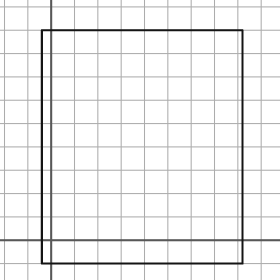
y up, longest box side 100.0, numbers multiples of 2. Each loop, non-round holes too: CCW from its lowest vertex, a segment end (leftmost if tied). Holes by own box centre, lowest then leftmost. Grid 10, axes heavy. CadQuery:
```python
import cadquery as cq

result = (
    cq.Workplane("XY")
    .moveTo(-4.0, -10.0)
    .lineTo(82.0, -10.0)
    .lineTo(82.0, 90.0)
    .lineTo(-4.0, 90.0)
    .close()
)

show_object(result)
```